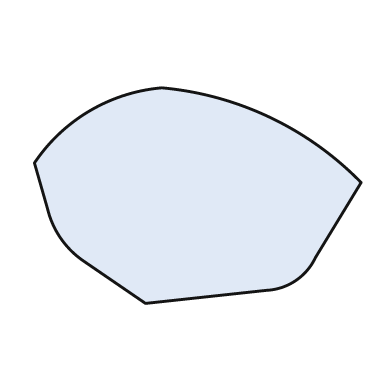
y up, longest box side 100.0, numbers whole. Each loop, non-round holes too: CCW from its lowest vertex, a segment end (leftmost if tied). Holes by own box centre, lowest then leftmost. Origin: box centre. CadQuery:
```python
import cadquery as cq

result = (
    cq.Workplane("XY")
    .moveTo(-16.0, -33.0)
    .lineTo(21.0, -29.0)
    .threePointArc((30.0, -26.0), (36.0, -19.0))
    .lineTo(50.0, 4.0)
    .threePointArc((22.0, 24.0), (-11.0, 33.0))
    .threePointArc((-33.0, 26.0), (-50.0, 10.0))
    .lineTo(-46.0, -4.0)
    .threePointArc((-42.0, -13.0), (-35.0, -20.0))
    .close()
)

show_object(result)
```